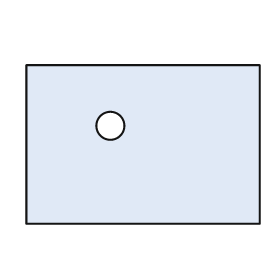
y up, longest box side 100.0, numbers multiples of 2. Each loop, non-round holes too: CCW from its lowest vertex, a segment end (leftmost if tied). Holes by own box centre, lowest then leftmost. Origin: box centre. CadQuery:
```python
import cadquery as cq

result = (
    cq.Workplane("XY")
    .moveTo(-50.0, -34.0)
    .lineTo(50.0, -34.0)
    .lineTo(50.0, 34.0)
    .lineTo(-50.0, 34.0)
    .close()
    .moveTo(-14.0, 8.0)
    .circle(6.0)
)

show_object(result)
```